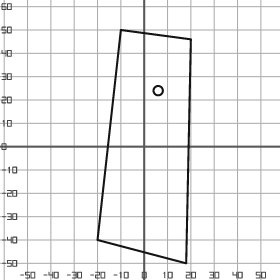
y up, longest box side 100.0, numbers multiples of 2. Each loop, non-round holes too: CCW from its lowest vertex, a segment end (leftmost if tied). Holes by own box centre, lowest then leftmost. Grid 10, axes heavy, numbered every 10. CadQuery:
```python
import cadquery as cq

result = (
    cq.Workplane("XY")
    .moveTo(18.0, -50.0)
    .lineTo(20.0, 46.0)
    .lineTo(-10.0, 50.0)
    .lineTo(-20.0, -40.0)
    .close()
    .moveTo(6.0, 24.0)
    .circle(2.0)
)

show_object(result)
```